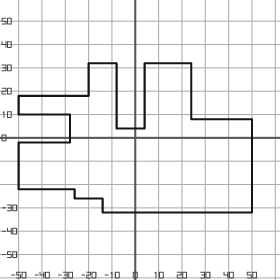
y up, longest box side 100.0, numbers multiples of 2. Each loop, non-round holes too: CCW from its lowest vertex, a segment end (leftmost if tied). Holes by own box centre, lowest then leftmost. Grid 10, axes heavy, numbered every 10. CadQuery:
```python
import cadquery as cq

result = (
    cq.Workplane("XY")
    .moveTo(-14.0, -32.0)
    .lineTo(50.0, -32.0)
    .lineTo(50.0, 8.0)
    .lineTo(24.0, 8.0)
    .lineTo(24.0, 32.0)
    .lineTo(4.0, 32.0)
    .lineTo(4.0, 4.0)
    .lineTo(-8.0, 4.0)
    .lineTo(-8.0, 32.0)
    .lineTo(-20.0, 32.0)
    .lineTo(-20.0, 18.0)
    .lineTo(-50.0, 18.0)
    .lineTo(-50.0, 10.0)
    .lineTo(-28.0, 10.0)
    .lineTo(-28.0, -2.0)
    .lineTo(-50.0, -2.0)
    .lineTo(-50.0, -22.0)
    .lineTo(-26.0, -22.0)
    .lineTo(-26.0, -26.0)
    .lineTo(-14.0, -26.0)
    .close()
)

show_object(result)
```